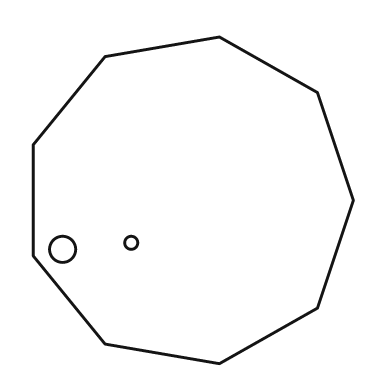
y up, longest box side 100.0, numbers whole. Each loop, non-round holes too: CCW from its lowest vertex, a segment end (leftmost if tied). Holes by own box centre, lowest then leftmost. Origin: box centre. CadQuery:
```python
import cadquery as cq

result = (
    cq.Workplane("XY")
    .moveTo(8.0, -50.0)
    .lineTo(38.0, -33.0)
    .lineTo(49.0, 0.0)
    .lineTo(38.0, 33.0)
    .lineTo(8.0, 50.0)
    .lineTo(-27.0, 44.0)
    .lineTo(-49.0, 17.0)
    .lineTo(-49.0, -17.0)
    .lineTo(-27.0, -44.0)
    .close()
    .moveTo(-40.0, -15.0)
    .circle(4.0)
    .moveTo(-19.0, -13.0)
    .circle(2.0)
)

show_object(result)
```